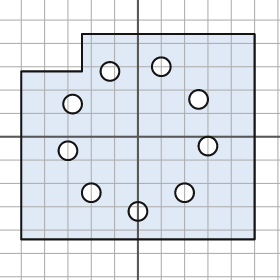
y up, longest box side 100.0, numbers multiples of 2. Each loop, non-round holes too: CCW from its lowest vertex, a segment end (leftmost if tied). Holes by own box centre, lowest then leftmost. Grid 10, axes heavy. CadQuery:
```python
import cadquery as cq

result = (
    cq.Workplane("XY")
    .moveTo(-50.0, -44.0)
    .lineTo(50.0, -44.0)
    .lineTo(50.0, 44.0)
    .lineTo(-24.0, 44.0)
    .lineTo(-24.0, 28.0)
    .lineTo(-50.0, 28.0)
    .close()
    .moveTo(0.0, -32.0)
    .circle(4.0)
    .moveTo(-20.0, -24.0)
    .circle(4.0)
    .moveTo(20.0, -24.0)
    .circle(4.0)
    .moveTo(-30.0, -6.0)
    .circle(4.0)
    .moveTo(30.0, -4.0)
    .circle(4.0)
    .moveTo(-28.0, 14.0)
    .circle(4.0)
    .moveTo(26.0, 16.0)
    .circle(4.0)
    .moveTo(-12.0, 28.0)
    .circle(4.0)
    .moveTo(10.0, 30.0)
    .circle(4.0)
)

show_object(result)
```